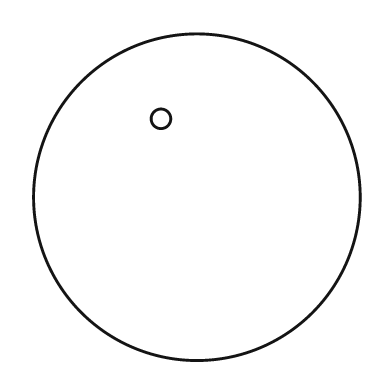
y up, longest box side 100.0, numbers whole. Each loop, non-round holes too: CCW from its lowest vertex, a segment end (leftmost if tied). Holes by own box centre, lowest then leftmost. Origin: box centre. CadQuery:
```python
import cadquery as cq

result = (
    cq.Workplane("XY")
    .moveTo(0.0, 0.0)
    .circle(50.0)
    .moveTo(-11.0, 24.0)
    .circle(3.0)
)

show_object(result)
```